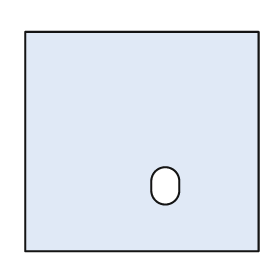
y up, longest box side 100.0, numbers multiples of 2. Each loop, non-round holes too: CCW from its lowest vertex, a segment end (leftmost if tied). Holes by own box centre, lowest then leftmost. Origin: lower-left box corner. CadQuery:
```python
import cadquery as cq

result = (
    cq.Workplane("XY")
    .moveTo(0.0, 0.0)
    .lineTo(100.0, 0.0)
    .lineTo(100.0, 94.0)
    .lineTo(0.0, 94.0)
    .close()
    .moveTo(54.0, 26.0)
    .threePointArc((60.0, 20.0), (66.0, 26.0))
    .lineTo(66.0, 30.0)
    .threePointArc((60.0, 36.0), (54.0, 30.0))
    .close()
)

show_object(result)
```